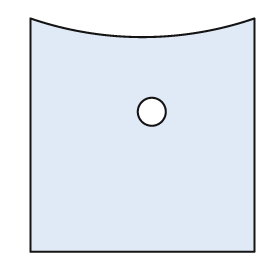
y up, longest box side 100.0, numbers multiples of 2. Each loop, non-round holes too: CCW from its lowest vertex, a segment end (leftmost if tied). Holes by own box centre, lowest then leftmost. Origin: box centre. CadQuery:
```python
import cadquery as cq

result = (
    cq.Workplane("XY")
    .moveTo(-48.0, -50.0)
    .lineTo(48.0, -50.0)
    .lineTo(48.0, 50.0)
    .threePointArc((0.0, 42.0), (-48.0, 50.0))
    .close()
    .moveTo(4.0, 10.0)
    .circle(6.0)
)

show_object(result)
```